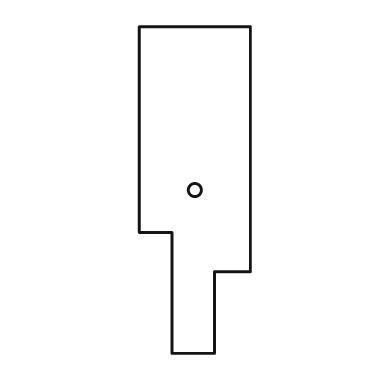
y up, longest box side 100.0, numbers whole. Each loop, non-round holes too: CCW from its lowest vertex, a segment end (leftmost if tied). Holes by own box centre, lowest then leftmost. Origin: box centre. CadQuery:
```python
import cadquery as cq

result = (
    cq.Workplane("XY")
    .moveTo(-7.0, -50.0)
    .lineTo(6.0, -50.0)
    .lineTo(6.0, -25.0)
    .lineTo(17.0, -25.0)
    .lineTo(17.0, 50.0)
    .lineTo(-17.0, 50.0)
    .lineTo(-17.0, -13.0)
    .lineTo(-7.0, -13.0)
    .close()
    .moveTo(0.0, 0.0)
    .circle(2.0)
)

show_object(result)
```